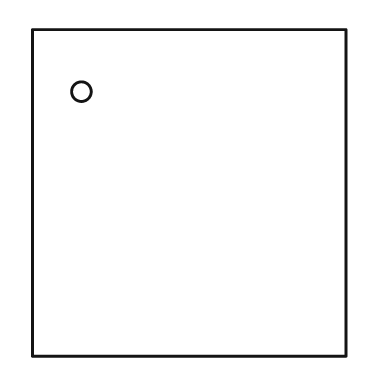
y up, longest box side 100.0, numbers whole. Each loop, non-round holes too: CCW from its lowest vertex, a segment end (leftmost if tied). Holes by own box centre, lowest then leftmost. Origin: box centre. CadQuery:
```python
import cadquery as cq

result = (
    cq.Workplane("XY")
    .moveTo(-48.0, -50.0)
    .lineTo(48.0, -50.0)
    .lineTo(48.0, 50.0)
    .lineTo(-48.0, 50.0)
    .close()
    .moveTo(-33.0, 31.0)
    .circle(3.0)
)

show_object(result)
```